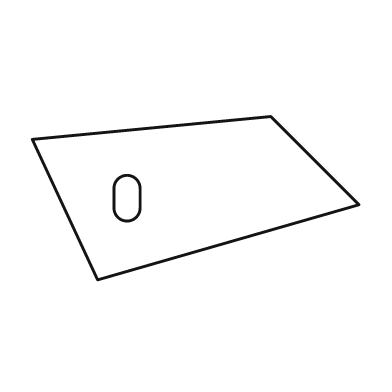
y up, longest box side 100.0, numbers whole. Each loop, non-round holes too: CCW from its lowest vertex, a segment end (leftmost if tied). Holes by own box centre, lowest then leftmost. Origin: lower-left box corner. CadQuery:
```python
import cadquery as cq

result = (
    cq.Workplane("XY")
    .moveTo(20.0, 0.0)
    .lineTo(100.0, 23.0)
    .lineTo(73.0, 50.0)
    .lineTo(0.0, 43.0)
    .close()
    .moveTo(25.0, 22.0)
    .threePointArc((29.0, 18.0), (33.0, 22.0))
    .lineTo(33.0, 28.0)
    .threePointArc((29.0, 32.0), (25.0, 28.0))
    .close()
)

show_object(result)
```